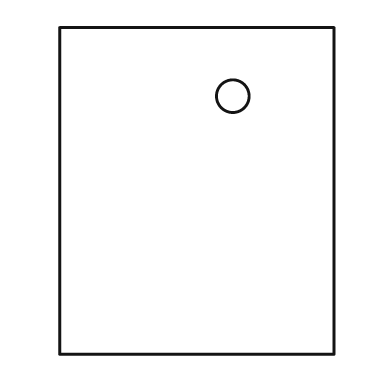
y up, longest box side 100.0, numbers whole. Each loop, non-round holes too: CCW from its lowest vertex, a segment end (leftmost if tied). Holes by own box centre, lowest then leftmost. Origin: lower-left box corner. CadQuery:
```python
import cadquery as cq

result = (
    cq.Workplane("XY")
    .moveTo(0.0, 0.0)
    .lineTo(84.0, 0.0)
    .lineTo(84.0, 100.0)
    .lineTo(0.0, 100.0)
    .close()
    .moveTo(53.0, 79.0)
    .circle(5.0)
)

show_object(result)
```